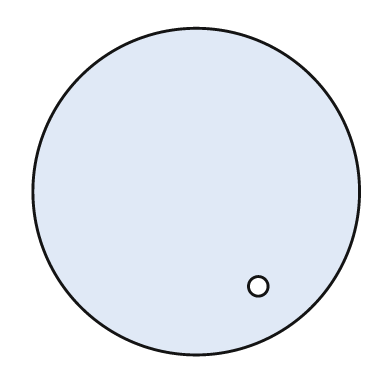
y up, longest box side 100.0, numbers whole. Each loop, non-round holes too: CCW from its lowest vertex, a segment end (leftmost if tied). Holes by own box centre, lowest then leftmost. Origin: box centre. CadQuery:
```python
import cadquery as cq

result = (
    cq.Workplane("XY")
    .moveTo(0.0, 0.0)
    .circle(50.0)
    .moveTo(19.0, -29.0)
    .circle(3.0)
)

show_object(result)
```